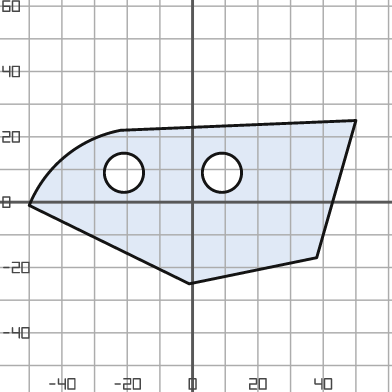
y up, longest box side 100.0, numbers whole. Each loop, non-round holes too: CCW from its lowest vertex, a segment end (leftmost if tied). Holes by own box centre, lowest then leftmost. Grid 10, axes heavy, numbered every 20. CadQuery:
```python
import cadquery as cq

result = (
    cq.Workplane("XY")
    .moveTo(-1.0, -25.0)
    .lineTo(38.0, -17.0)
    .lineTo(50.0, 25.0)
    .lineTo(-22.0, 22.0)
    .threePointArc((-39.0, 14.0), (-50.0, -1.0))
    .close()
    .moveTo(-21.0, 9.0)
    .circle(6.0)
    .moveTo(9.0, 9.0)
    .circle(6.0)
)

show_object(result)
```